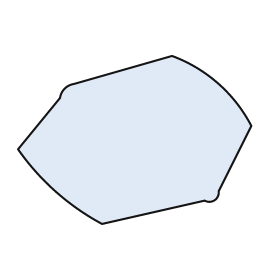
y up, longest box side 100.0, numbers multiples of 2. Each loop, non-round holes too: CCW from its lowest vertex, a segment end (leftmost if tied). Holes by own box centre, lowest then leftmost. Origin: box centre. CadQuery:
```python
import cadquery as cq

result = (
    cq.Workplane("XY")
    .moveTo(-14.0, -36.0)
    .lineTo(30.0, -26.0)
    .threePointArc((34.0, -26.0), (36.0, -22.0))
    .lineTo(50.0, 6.0)
    .threePointArc((36.0, 24.0), (16.0, 36.0))
    .lineTo(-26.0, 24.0)
    .threePointArc((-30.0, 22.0), (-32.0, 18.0))
    .lineTo(-50.0, -4.0)
    .threePointArc((-34.0, -22.0), (-14.0, -36.0))
    .close()
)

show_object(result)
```